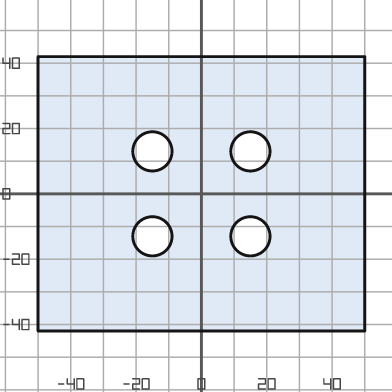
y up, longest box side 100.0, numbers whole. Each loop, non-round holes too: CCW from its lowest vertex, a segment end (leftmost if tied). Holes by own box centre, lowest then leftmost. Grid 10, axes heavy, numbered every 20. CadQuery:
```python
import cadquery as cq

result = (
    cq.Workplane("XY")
    .moveTo(-50.0, -42.0)
    .lineTo(50.0, -42.0)
    .lineTo(50.0, 42.0)
    .lineTo(-50.0, 42.0)
    .close()
    .moveTo(-15.0, -13.0)
    .circle(6.0)
    .moveTo(15.0, -13.0)
    .circle(6.0)
    .moveTo(-15.0, 13.0)
    .circle(6.0)
    .moveTo(15.0, 13.0)
    .circle(6.0)
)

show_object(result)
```